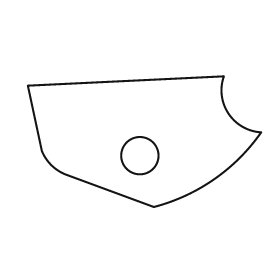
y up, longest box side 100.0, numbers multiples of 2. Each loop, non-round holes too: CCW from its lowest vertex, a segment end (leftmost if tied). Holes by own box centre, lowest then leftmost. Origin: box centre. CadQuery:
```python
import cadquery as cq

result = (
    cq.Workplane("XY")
    .moveTo(4.0, -28.0)
    .threePointArc((30.0, -16.0), (50.0, 4.0))
    .threePointArc((36.0, 12.0), (34.0, 28.0))
    .lineTo(-50.0, 24.0)
    .lineTo(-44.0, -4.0)
    .threePointArc((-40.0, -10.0), (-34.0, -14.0))
    .close()
    .moveTo(-2.0, -6.0)
    .circle(8.0)
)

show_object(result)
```